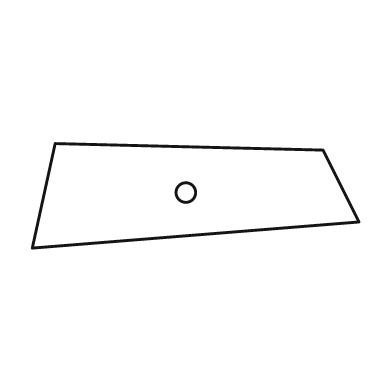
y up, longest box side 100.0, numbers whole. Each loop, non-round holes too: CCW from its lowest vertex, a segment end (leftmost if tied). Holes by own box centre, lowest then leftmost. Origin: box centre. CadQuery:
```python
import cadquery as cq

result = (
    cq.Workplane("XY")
    .moveTo(-50.0, -16.0)
    .lineTo(50.0, -8.0)
    .lineTo(39.0, 14.0)
    .lineTo(-43.0, 16.0)
    .close()
    .moveTo(-3.0, 1.0)
    .circle(3.0)
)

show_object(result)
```